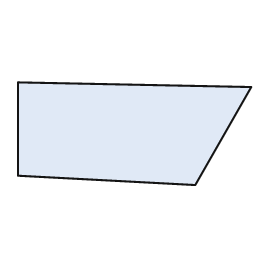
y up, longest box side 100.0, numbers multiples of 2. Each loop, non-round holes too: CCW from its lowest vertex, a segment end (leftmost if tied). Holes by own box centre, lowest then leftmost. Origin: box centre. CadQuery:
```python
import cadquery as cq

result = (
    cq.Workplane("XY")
    .moveTo(26.0, -22.0)
    .lineTo(50.0, 20.0)
    .lineTo(-50.0, 22.0)
    .lineTo(-50.0, -18.0)
    .close()
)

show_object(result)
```